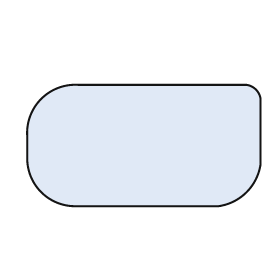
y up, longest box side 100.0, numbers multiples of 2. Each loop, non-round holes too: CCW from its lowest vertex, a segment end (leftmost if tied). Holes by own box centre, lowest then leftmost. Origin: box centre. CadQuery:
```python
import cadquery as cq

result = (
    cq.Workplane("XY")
    .moveTo(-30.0, -26.0)
    .lineTo(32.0, -26.0)
    .threePointArc((44.0, -20.0), (50.0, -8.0))
    .lineTo(50.0, 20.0)
    .threePointArc((48.0, 24.0), (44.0, 26.0))
    .lineTo(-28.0, 26.0)
    .threePointArc((-44.0, 20.0), (-50.0, 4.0))
    .lineTo(-50.0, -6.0)
    .threePointArc((-44.0, -20.0), (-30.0, -26.0))
    .close()
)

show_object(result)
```